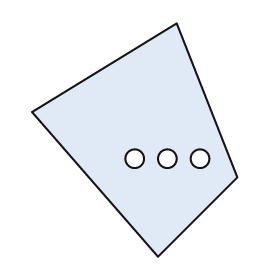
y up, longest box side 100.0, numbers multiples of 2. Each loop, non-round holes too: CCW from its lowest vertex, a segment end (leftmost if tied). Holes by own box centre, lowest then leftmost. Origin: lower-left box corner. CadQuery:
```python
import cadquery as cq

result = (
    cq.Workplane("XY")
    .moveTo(54.0, 0.0)
    .lineTo(88.0, 34.0)
    .lineTo(62.0, 100.0)
    .lineTo(0.0, 62.0)
    .close()
    .moveTo(44.0, 42.0)
    .circle(4.0)
    .moveTo(58.0, 42.0)
    .circle(4.0)
    .moveTo(72.0, 42.0)
    .circle(4.0)
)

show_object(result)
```